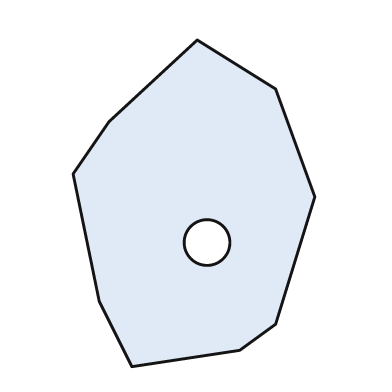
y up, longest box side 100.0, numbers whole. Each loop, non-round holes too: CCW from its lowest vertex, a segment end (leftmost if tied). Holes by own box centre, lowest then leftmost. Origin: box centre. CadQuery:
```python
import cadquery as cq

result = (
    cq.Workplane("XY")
    .moveTo(-19.0, -50.0)
    .lineTo(14.0, -45.0)
    .lineTo(25.0, -37.0)
    .lineTo(37.0, 2.0)
    .lineTo(25.0, 35.0)
    .lineTo(1.0, 50.0)
    .lineTo(-26.0, 25.0)
    .lineTo(-37.0, 9.0)
    .lineTo(-29.0, -30.0)
    .close()
    .moveTo(4.0, -12.0)
    .circle(7.0)
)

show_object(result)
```